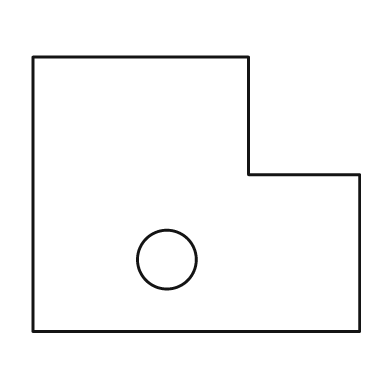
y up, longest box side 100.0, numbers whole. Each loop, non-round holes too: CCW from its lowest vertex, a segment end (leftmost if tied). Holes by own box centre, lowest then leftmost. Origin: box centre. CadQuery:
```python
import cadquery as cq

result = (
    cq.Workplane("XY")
    .moveTo(-50.0, -42.0)
    .lineTo(50.0, -42.0)
    .lineTo(50.0, 6.0)
    .lineTo(16.0, 6.0)
    .lineTo(16.0, 42.0)
    .lineTo(-50.0, 42.0)
    .close()
    .moveTo(-9.0, -20.0)
    .circle(9.0)
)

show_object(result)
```